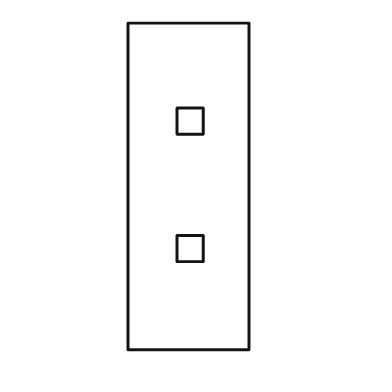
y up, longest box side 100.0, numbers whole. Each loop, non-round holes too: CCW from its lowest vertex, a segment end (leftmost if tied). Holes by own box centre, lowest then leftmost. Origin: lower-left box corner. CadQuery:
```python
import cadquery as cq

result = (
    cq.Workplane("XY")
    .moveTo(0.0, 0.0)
    .lineTo(37.0, 0.0)
    .lineTo(37.0, 100.0)
    .lineTo(0.0, 100.0)
    .close()
    .moveTo(15.0, 27.0)
    .lineTo(23.0, 27.0)
    .lineTo(23.0, 35.0)
    .lineTo(15.0, 35.0)
    .close()
    .moveTo(15.0, 66.0)
    .lineTo(23.0, 66.0)
    .lineTo(23.0, 74.0)
    .lineTo(15.0, 74.0)
    .close()
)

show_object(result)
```